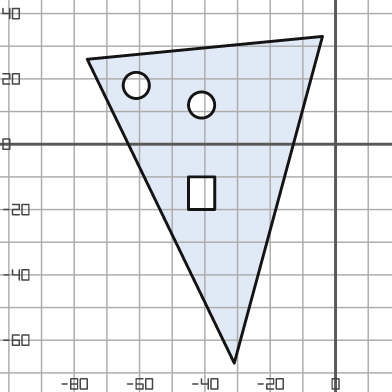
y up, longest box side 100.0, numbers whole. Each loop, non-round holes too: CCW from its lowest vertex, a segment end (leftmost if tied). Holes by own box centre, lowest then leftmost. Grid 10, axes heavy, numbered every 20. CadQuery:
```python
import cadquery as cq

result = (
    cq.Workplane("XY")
    .moveTo(-31.0, -67.0)
    .lineTo(-4.0, 33.0)
    .lineTo(-76.0, 26.0)
    .close()
    .moveTo(-45.0, -20.0)
    .lineTo(-37.0, -20.0)
    .lineTo(-37.0, -10.0)
    .lineTo(-45.0, -10.0)
    .close()
    .moveTo(-41.0, 12.0)
    .circle(4.0)
    .moveTo(-61.0, 18.0)
    .circle(4.0)
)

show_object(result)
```